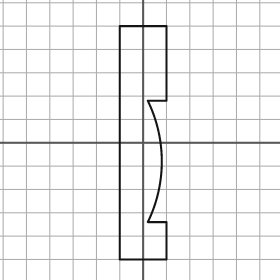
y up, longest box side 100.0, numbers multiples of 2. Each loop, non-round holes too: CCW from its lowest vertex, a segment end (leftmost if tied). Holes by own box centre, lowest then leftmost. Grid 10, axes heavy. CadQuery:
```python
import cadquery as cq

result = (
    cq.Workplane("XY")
    .moveTo(-10.0, -50.0)
    .lineTo(10.0, -50.0)
    .lineTo(10.0, -34.0)
    .lineTo(2.0, -34.0)
    .threePointArc((8.0, -8.0), (2.0, 18.0))
    .lineTo(10.0, 18.0)
    .lineTo(10.0, 50.0)
    .lineTo(-10.0, 50.0)
    .close()
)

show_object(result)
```